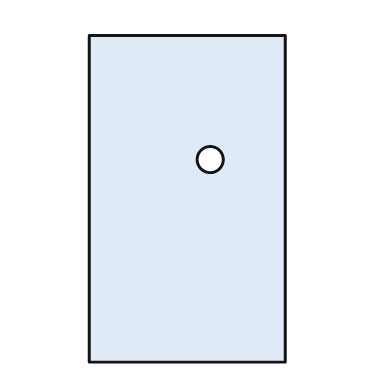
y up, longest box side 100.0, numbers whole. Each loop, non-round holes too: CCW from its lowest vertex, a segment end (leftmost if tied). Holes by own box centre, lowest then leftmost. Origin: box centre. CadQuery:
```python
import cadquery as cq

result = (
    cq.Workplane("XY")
    .moveTo(-30.0, -50.0)
    .lineTo(30.0, -50.0)
    .lineTo(30.0, 50.0)
    .lineTo(-30.0, 50.0)
    .close()
    .moveTo(7.0, 12.0)
    .circle(4.0)
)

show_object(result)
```